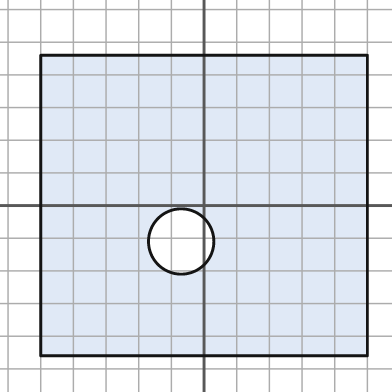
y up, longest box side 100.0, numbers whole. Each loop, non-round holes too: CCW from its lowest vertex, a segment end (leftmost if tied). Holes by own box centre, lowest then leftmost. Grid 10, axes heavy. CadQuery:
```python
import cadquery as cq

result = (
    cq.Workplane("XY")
    .moveTo(-50.0, -46.0)
    .lineTo(50.0, -46.0)
    .lineTo(50.0, 46.0)
    .lineTo(-50.0, 46.0)
    .close()
    .moveTo(-7.0, -11.0)
    .circle(10.0)
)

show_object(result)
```